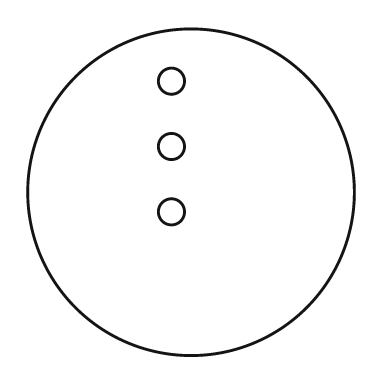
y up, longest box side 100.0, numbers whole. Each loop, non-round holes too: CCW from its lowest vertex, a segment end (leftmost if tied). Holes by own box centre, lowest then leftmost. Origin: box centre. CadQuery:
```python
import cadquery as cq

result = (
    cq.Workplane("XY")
    .moveTo(0.0, 0.0)
    .circle(50.0)
    .moveTo(-6.0, -6.0)
    .circle(4.0)
    .moveTo(-6.0, 14.0)
    .circle(4.0)
    .moveTo(-6.0, 34.0)
    .circle(4.0)
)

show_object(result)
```